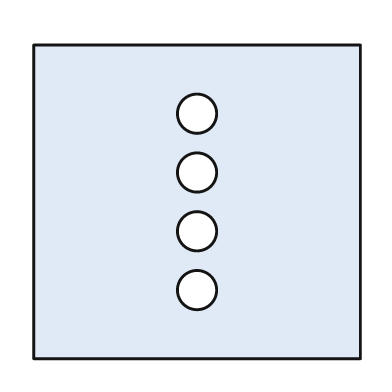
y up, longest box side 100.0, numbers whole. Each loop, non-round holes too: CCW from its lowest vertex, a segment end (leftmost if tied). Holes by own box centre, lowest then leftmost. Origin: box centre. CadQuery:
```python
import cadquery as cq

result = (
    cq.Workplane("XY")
    .moveTo(-50.0, -48.0)
    .lineTo(50.0, -48.0)
    .lineTo(50.0, 48.0)
    .lineTo(-50.0, 48.0)
    .close()
    .moveTo(0.0, -27.0)
    .circle(6.0)
    .moveTo(0.0, -9.0)
    .circle(6.0)
    .moveTo(0.0, 9.0)
    .circle(6.0)
    .moveTo(0.0, 27.0)
    .circle(6.0)
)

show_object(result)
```